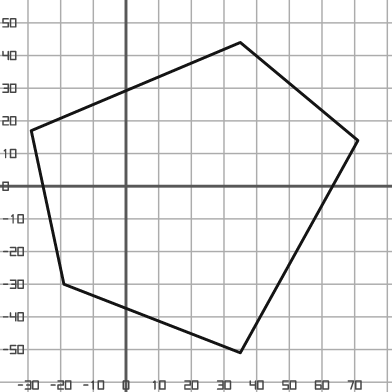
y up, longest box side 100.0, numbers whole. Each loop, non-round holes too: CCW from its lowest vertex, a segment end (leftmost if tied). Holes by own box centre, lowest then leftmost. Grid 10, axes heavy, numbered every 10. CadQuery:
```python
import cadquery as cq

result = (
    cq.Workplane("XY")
    .moveTo(35.0, -51.0)
    .lineTo(71.0, 14.0)
    .lineTo(35.0, 44.0)
    .lineTo(-29.0, 17.0)
    .lineTo(-19.0, -30.0)
    .close()
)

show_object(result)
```